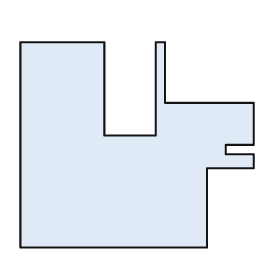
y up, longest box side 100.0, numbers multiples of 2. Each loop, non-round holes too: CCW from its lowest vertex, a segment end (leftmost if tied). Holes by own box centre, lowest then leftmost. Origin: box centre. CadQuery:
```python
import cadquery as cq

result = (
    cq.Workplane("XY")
    .moveTo(-50.0, -44.0)
    .lineTo(30.0, -44.0)
    .lineTo(30.0, -10.0)
    .lineTo(50.0, -10.0)
    .lineTo(50.0, -4.0)
    .lineTo(38.0, -4.0)
    .lineTo(38.0, 0.0)
    .lineTo(50.0, 0.0)
    .lineTo(50.0, 18.0)
    .lineTo(12.0, 18.0)
    .lineTo(12.0, 44.0)
    .lineTo(8.0, 44.0)
    .lineTo(8.0, 4.0)
    .lineTo(-14.0, 4.0)
    .lineTo(-14.0, 44.0)
    .lineTo(-50.0, 44.0)
    .close()
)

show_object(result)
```